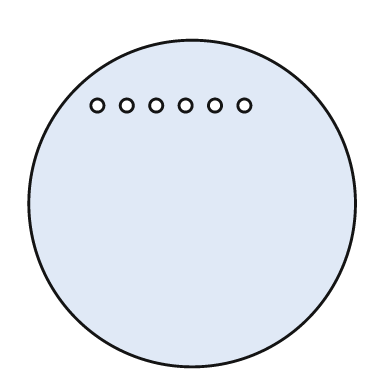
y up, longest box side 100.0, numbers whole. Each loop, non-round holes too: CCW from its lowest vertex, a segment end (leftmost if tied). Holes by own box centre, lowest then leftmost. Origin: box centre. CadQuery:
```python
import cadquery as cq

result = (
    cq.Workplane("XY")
    .moveTo(0.0, 0.0)
    .circle(50.0)
    .moveTo(-29.0, 30.0)
    .circle(2.0)
    .moveTo(-20.0, 30.0)
    .circle(2.0)
    .moveTo(-11.0, 30.0)
    .circle(2.0)
    .moveTo(-2.0, 30.0)
    .circle(2.0)
    .moveTo(7.0, 30.0)
    .circle(2.0)
    .moveTo(16.0, 30.0)
    .circle(2.0)
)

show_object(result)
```